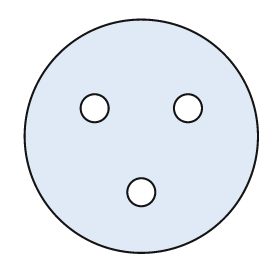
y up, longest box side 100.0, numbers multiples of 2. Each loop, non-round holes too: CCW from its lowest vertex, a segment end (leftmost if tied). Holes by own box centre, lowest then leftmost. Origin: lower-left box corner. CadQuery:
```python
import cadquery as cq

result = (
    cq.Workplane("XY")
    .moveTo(50.0, 50.0)
    .circle(50.0)
    .moveTo(50.0, 26.0)
    .circle(6.0)
    .moveTo(30.0, 62.0)
    .circle(6.0)
    .moveTo(70.0, 62.0)
    .circle(6.0)
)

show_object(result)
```